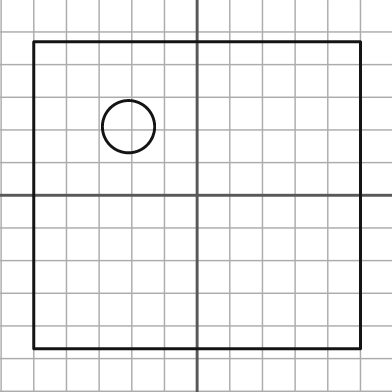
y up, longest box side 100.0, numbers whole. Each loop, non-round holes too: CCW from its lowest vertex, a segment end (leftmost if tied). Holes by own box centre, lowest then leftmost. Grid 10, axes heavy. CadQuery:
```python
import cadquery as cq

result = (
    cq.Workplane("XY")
    .moveTo(-50.0, -47.0)
    .lineTo(50.0, -47.0)
    .lineTo(50.0, 47.0)
    .lineTo(-50.0, 47.0)
    .close()
    .moveTo(-21.0, 21.0)
    .circle(8.0)
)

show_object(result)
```